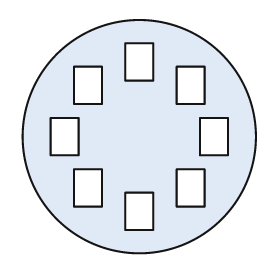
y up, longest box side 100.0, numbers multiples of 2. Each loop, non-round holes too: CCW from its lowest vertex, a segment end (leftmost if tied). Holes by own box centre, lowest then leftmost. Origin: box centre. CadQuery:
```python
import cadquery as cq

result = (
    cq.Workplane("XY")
    .moveTo(0.0, 0.0)
    .circle(50.0)
    .moveTo(-6.0, -40.0)
    .lineTo(6.0, -40.0)
    .lineTo(6.0, -24.0)
    .lineTo(-6.0, -24.0)
    .close()
    .moveTo(-28.0, -30.0)
    .lineTo(-16.0, -30.0)
    .lineTo(-16.0, -14.0)
    .lineTo(-28.0, -14.0)
    .close()
    .moveTo(16.0, -30.0)
    .lineTo(28.0, -30.0)
    .lineTo(28.0, -14.0)
    .lineTo(16.0, -14.0)
    .close()
    .moveTo(-38.0, -8.0)
    .lineTo(-26.0, -8.0)
    .lineTo(-26.0, 8.0)
    .lineTo(-38.0, 8.0)
    .close()
    .moveTo(26.0, -8.0)
    .lineTo(38.0, -8.0)
    .lineTo(38.0, 8.0)
    .lineTo(26.0, 8.0)
    .close()
    .moveTo(-28.0, 14.0)
    .lineTo(-16.0, 14.0)
    .lineTo(-16.0, 30.0)
    .lineTo(-28.0, 30.0)
    .close()
    .moveTo(16.0, 14.0)
    .lineTo(28.0, 14.0)
    .lineTo(28.0, 30.0)
    .lineTo(16.0, 30.0)
    .close()
    .moveTo(-6.0, 24.0)
    .lineTo(6.0, 24.0)
    .lineTo(6.0, 40.0)
    .lineTo(-6.0, 40.0)
    .close()
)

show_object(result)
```